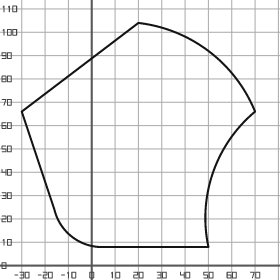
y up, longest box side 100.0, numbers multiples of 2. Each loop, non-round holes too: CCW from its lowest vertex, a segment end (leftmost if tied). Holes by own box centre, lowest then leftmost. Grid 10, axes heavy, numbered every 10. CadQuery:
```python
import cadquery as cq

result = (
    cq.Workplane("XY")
    .moveTo(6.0, 8.0)
    .lineTo(50.0, 8.0)
    .threePointArc((52.0, 40.0), (70.0, 66.0))
    .threePointArc((50.0, 92.0), (20.0, 104.0))
    .lineTo(-30.0, 66.0)
    .lineTo(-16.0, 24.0)
    .threePointArc((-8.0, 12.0), (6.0, 8.0))
    .close()
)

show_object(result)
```